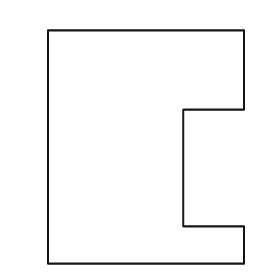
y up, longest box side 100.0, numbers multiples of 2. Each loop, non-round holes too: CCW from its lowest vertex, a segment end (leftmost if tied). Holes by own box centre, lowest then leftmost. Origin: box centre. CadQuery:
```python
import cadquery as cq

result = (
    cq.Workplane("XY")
    .moveTo(-42.0, -50.0)
    .lineTo(42.0, -50.0)
    .lineTo(42.0, -34.0)
    .lineTo(16.0, -34.0)
    .lineTo(16.0, 16.0)
    .lineTo(42.0, 16.0)
    .lineTo(42.0, 50.0)
    .lineTo(-42.0, 50.0)
    .close()
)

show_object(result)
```